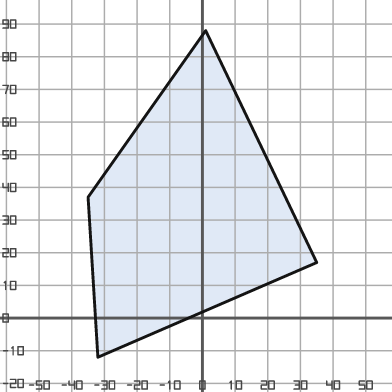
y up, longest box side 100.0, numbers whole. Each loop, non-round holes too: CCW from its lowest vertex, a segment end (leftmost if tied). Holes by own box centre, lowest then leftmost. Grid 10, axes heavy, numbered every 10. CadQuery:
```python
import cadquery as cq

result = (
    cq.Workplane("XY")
    .moveTo(-32.0, -12.0)
    .lineTo(35.0, 17.0)
    .lineTo(1.0, 88.0)
    .lineTo(-35.0, 37.0)
    .close()
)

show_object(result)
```